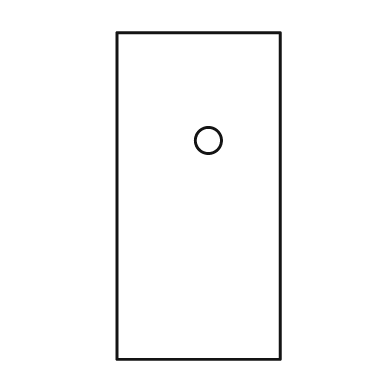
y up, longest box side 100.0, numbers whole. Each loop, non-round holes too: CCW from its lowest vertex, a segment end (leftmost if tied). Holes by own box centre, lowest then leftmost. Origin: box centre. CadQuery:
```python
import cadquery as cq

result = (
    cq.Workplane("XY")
    .moveTo(-25.0, -50.0)
    .lineTo(25.0, -50.0)
    .lineTo(25.0, 50.0)
    .lineTo(-25.0, 50.0)
    .close()
    .moveTo(3.0, 17.0)
    .circle(4.0)
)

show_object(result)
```